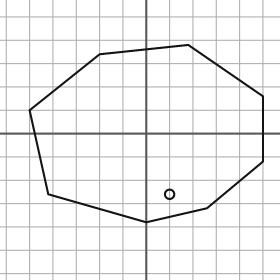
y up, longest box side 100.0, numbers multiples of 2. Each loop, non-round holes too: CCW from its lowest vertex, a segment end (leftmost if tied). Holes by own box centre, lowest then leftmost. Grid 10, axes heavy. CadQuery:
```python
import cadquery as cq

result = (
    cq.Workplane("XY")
    .moveTo(0.0, -38.0)
    .lineTo(26.0, -32.0)
    .lineTo(50.0, -12.0)
    .lineTo(50.0, 16.0)
    .lineTo(18.0, 38.0)
    .lineTo(-20.0, 34.0)
    .lineTo(-50.0, 10.0)
    .lineTo(-42.0, -26.0)
    .close()
    .moveTo(10.0, -26.0)
    .circle(2.0)
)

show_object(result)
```